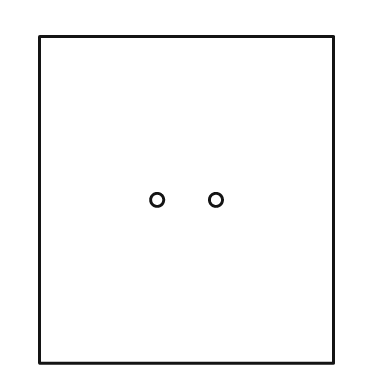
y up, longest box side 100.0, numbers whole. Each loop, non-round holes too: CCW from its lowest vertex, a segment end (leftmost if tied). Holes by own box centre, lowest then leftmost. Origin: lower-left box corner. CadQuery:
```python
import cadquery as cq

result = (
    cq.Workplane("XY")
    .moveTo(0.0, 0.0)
    .lineTo(90.0, 0.0)
    .lineTo(90.0, 100.0)
    .lineTo(0.0, 100.0)
    .close()
    .moveTo(36.0, 50.0)
    .circle(2.0)
    .moveTo(54.0, 50.0)
    .circle(2.0)
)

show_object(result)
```